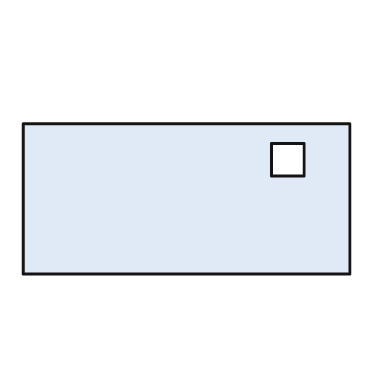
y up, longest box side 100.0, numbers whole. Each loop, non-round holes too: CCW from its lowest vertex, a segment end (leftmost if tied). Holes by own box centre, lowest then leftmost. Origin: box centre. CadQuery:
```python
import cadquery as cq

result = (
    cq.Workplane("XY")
    .moveTo(-50.0, -23.0)
    .lineTo(50.0, -23.0)
    .lineTo(50.0, 23.0)
    .lineTo(-50.0, 23.0)
    .close()
    .moveTo(26.0, 7.0)
    .lineTo(36.0, 7.0)
    .lineTo(36.0, 17.0)
    .lineTo(26.0, 17.0)
    .close()
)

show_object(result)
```